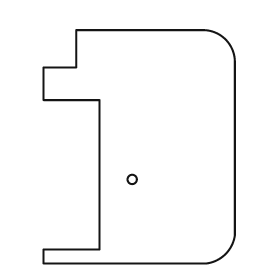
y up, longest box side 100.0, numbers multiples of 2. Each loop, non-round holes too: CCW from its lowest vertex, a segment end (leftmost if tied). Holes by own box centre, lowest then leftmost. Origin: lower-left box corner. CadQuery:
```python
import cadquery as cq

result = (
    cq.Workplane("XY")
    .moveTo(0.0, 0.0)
    .lineTo(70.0, 0.0)
    .threePointArc((78.0, 4.0), (82.0, 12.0))
    .lineTo(82.0, 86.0)
    .threePointArc((78.0, 96.0), (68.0, 100.0))
    .lineTo(14.0, 100.0)
    .lineTo(14.0, 84.0)
    .lineTo(0.0, 84.0)
    .lineTo(0.0, 70.0)
    .lineTo(24.0, 70.0)
    .lineTo(24.0, 6.0)
    .lineTo(0.0, 6.0)
    .close()
    .moveTo(38.0, 36.0)
    .circle(2.0)
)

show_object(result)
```